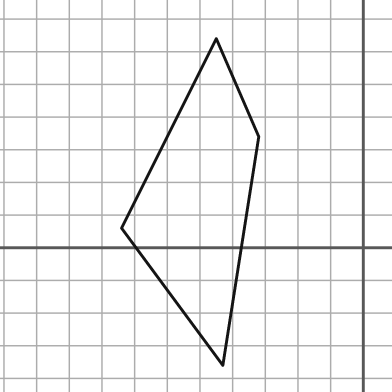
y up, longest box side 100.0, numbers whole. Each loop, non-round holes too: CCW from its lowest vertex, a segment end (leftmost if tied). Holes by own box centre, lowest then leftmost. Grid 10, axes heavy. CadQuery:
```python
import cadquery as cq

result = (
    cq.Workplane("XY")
    .moveTo(-43.0, -36.0)
    .lineTo(-32.0, 34.0)
    .lineTo(-45.0, 64.0)
    .lineTo(-74.0, 6.0)
    .close()
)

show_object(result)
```